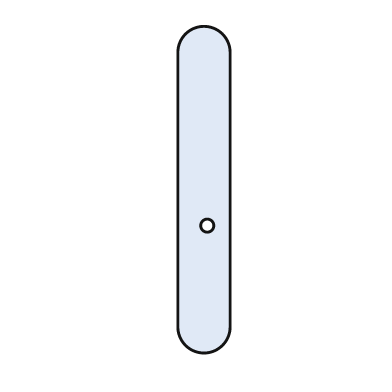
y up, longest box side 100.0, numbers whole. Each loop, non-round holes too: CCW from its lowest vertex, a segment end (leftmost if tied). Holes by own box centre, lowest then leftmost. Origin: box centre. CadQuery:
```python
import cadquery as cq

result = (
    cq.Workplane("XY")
    .moveTo(-8.0, -42.0)
    .threePointArc((0.0, -50.0), (8.0, -42.0))
    .lineTo(8.0, 42.0)
    .threePointArc((0.0, 50.0), (-8.0, 42.0))
    .close()
    .moveTo(1.0, -11.0)
    .circle(2.0)
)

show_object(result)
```